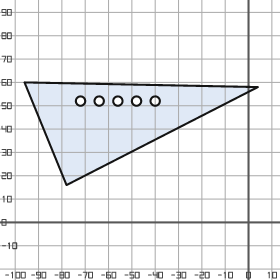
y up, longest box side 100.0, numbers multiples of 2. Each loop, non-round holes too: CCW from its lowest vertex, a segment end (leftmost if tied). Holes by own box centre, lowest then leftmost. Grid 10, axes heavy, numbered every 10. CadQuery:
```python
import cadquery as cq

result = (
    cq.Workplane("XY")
    .moveTo(-78.0, 16.0)
    .lineTo(4.0, 58.0)
    .lineTo(-96.0, 60.0)
    .close()
    .moveTo(-72.0, 52.0)
    .circle(2.0)
    .moveTo(-64.0, 52.0)
    .circle(2.0)
    .moveTo(-56.0, 52.0)
    .circle(2.0)
    .moveTo(-48.0, 52.0)
    .circle(2.0)
    .moveTo(-40.0, 52.0)
    .circle(2.0)
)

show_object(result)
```